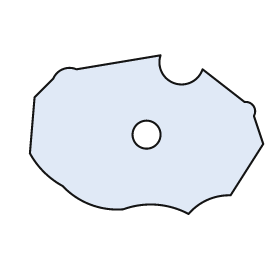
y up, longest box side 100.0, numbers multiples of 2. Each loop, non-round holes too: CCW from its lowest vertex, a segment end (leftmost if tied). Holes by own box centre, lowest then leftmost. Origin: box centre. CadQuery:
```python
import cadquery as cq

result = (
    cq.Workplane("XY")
    .moveTo(18.0, -34.0)
    .threePointArc((26.0, -28.0), (36.0, -26.0))
    .lineTo(50.0, -4.0)
    .lineTo(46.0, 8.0)
    .threePointArc((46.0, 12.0), (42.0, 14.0))
    .lineTo(24.0, 28.0)
    .threePointArc((12.0, 22.0), (6.0, 34.0))
    .lineTo(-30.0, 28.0)
    .threePointArc((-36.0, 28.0), (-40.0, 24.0))
    .lineTo(-48.0, 16.0)
    .lineTo(-50.0, -8.0)
    .threePointArc((-44.0, -16.0), (-36.0, -22.0))
    .threePointArc((-24.0, -30.0), (-10.0, -32.0))
    .threePointArc((4.0, -30.0), (18.0, -34.0))
    .close()
    .moveTo(0.0, 0.0)
    .circle(6.0)
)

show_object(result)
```